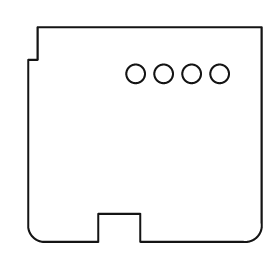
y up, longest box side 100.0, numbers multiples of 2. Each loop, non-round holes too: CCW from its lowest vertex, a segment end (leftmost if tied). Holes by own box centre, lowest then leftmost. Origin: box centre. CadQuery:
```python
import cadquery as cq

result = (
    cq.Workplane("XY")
    .moveTo(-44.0, -46.0)
    .lineTo(-20.0, -46.0)
    .lineTo(-20.0, -34.0)
    .lineTo(-2.0, -34.0)
    .lineTo(-2.0, -46.0)
    .lineTo(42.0, -46.0)
    .threePointArc((48.0, -44.0), (50.0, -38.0))
    .lineTo(50.0, 46.0)
    .lineTo(-46.0, 46.0)
    .lineTo(-46.0, 32.0)
    .lineTo(-50.0, 32.0)
    .lineTo(-50.0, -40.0)
    .threePointArc((-48.0, -44.0), (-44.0, -46.0))
    .close()
    .moveTo(-4.0, 26.0)
    .circle(4.0)
    .moveTo(8.0, 26.0)
    .circle(4.0)
    .moveTo(20.0, 26.0)
    .circle(4.0)
    .moveTo(32.0, 26.0)
    .circle(4.0)
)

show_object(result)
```